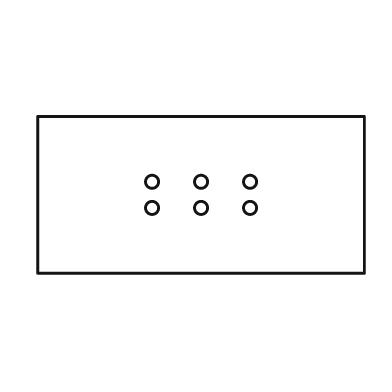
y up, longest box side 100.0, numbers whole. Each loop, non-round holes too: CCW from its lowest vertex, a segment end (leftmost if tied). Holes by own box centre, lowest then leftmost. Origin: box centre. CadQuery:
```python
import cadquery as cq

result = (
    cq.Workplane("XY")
    .moveTo(-50.0, -24.0)
    .lineTo(50.0, -24.0)
    .lineTo(50.0, 24.0)
    .lineTo(-50.0, 24.0)
    .close()
    .moveTo(-15.0, -4.0)
    .circle(2.0)
    .moveTo(0.0, -4.0)
    .circle(2.0)
    .moveTo(15.0, -4.0)
    .circle(2.0)
    .moveTo(-15.0, 4.0)
    .circle(2.0)
    .moveTo(0.0, 4.0)
    .circle(2.0)
    .moveTo(15.0, 4.0)
    .circle(2.0)
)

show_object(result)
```